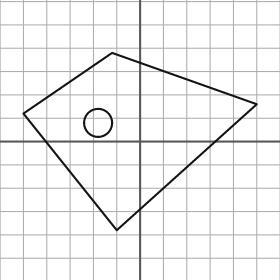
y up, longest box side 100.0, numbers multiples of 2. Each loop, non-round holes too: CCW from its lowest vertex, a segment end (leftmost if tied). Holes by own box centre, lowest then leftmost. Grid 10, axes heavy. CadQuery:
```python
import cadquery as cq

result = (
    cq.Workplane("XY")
    .moveTo(-10.0, -38.0)
    .lineTo(50.0, 16.0)
    .lineTo(-12.0, 38.0)
    .lineTo(-50.0, 12.0)
    .close()
    .moveTo(-18.0, 8.0)
    .circle(6.0)
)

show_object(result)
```